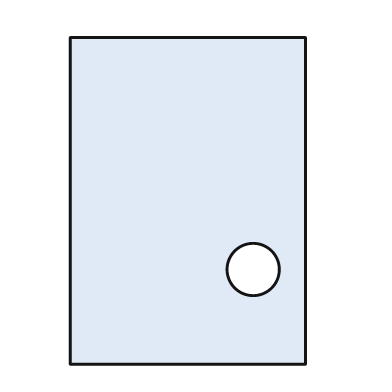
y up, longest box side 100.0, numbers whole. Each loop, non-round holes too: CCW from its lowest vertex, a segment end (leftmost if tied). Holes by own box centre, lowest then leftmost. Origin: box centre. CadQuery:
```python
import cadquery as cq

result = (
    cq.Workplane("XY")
    .moveTo(-36.0, -50.0)
    .lineTo(36.0, -50.0)
    .lineTo(36.0, 50.0)
    .lineTo(-36.0, 50.0)
    .close()
    .moveTo(20.0, -21.0)
    .circle(8.0)
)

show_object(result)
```